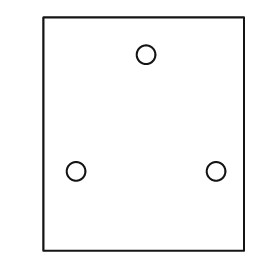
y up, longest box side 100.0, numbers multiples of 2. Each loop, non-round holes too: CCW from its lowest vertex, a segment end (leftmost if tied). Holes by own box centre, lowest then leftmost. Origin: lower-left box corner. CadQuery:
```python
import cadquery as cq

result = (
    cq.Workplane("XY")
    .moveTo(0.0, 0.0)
    .lineTo(86.0, 0.0)
    .lineTo(86.0, 100.0)
    .lineTo(0.0, 100.0)
    .close()
    .moveTo(14.0, 34.0)
    .circle(4.0)
    .moveTo(74.0, 34.0)
    .circle(4.0)
    .moveTo(44.0, 84.0)
    .circle(4.0)
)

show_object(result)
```